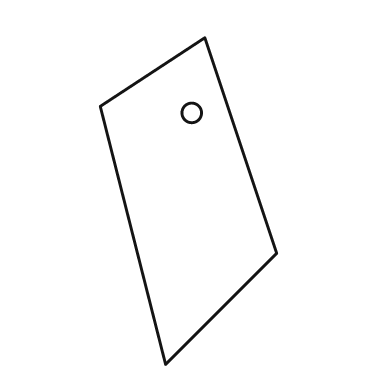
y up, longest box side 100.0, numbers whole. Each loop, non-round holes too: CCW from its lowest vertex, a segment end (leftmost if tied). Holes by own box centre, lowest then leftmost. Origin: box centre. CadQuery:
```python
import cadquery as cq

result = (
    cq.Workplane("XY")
    .moveTo(-7.0, -50.0)
    .lineTo(27.0, -16.0)
    .lineTo(5.0, 50.0)
    .lineTo(-27.0, 29.0)
    .close()
    .moveTo(1.0, 27.0)
    .circle(3.0)
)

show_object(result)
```